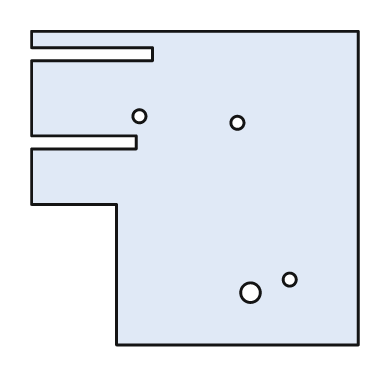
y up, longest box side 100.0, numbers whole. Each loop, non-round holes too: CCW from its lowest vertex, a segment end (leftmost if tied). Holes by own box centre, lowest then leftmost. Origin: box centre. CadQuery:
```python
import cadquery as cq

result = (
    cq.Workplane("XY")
    .moveTo(-24.0, -48.0)
    .lineTo(50.0, -48.0)
    .lineTo(50.0, 48.0)
    .lineTo(-50.0, 48.0)
    .lineTo(-50.0, 43.0)
    .lineTo(-13.0, 43.0)
    .lineTo(-13.0, 39.0)
    .lineTo(-50.0, 39.0)
    .lineTo(-50.0, 16.0)
    .lineTo(-18.0, 16.0)
    .lineTo(-18.0, 12.0)
    .lineTo(-50.0, 12.0)
    .lineTo(-50.0, -5.0)
    .lineTo(-24.0, -5.0)
    .close()
    .moveTo(17.0, -32.0)
    .circle(3.0)
    .moveTo(29.0, -28.0)
    .circle(2.0)
    .moveTo(13.0, 20.0)
    .circle(2.0)
    .moveTo(-17.0, 22.0)
    .circle(2.0)
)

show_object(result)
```